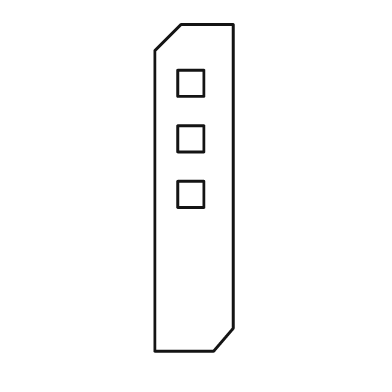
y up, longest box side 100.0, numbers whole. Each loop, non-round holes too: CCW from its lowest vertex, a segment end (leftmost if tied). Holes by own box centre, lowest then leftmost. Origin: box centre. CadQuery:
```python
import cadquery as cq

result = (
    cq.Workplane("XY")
    .moveTo(-12.0, -50.0)
    .lineTo(6.0, -50.0)
    .lineTo(12.0, -43.0)
    .lineTo(12.0, 50.0)
    .lineTo(-4.0, 50.0)
    .lineTo(-12.0, 42.0)
    .close()
    .moveTo(-5.0, -6.0)
    .lineTo(3.0, -6.0)
    .lineTo(3.0, 2.0)
    .lineTo(-5.0, 2.0)
    .close()
    .moveTo(-5.0, 11.0)
    .lineTo(3.0, 11.0)
    .lineTo(3.0, 19.0)
    .lineTo(-5.0, 19.0)
    .close()
    .moveTo(-5.0, 28.0)
    .lineTo(3.0, 28.0)
    .lineTo(3.0, 36.0)
    .lineTo(-5.0, 36.0)
    .close()
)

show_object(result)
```